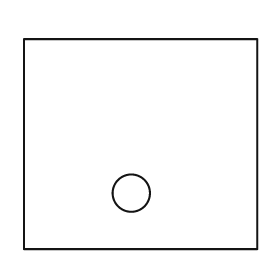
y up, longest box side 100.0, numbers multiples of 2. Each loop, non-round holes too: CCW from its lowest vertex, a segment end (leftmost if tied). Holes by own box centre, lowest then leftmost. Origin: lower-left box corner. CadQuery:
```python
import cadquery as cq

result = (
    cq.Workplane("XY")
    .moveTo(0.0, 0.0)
    .lineTo(100.0, 0.0)
    .lineTo(100.0, 90.0)
    .lineTo(0.0, 90.0)
    .close()
    .moveTo(46.0, 24.0)
    .circle(8.0)
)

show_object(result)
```